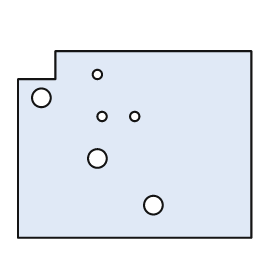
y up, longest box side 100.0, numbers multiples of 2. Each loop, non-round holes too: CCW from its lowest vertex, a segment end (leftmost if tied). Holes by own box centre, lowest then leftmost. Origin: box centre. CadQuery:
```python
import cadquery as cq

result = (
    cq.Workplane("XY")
    .moveTo(-50.0, -40.0)
    .lineTo(50.0, -40.0)
    .lineTo(50.0, 40.0)
    .lineTo(-34.0, 40.0)
    .lineTo(-34.0, 28.0)
    .lineTo(-50.0, 28.0)
    .close()
    .moveTo(8.0, -26.0)
    .circle(4.0)
    .moveTo(-16.0, -6.0)
    .circle(4.0)
    .moveTo(-14.0, 12.0)
    .circle(2.0)
    .moveTo(0.0, 12.0)
    .circle(2.0)
    .moveTo(-40.0, 20.0)
    .circle(4.0)
    .moveTo(-16.0, 30.0)
    .circle(2.0)
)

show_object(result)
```